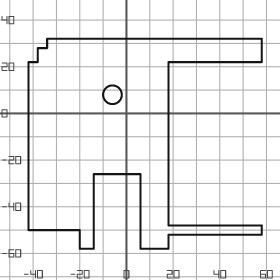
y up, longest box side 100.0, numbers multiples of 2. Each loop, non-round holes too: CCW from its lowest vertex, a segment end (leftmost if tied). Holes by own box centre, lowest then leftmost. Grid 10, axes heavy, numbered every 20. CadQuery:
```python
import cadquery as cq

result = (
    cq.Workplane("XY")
    .moveTo(-20.0, -58.0)
    .lineTo(-14.0, -58.0)
    .lineTo(-14.0, -26.0)
    .lineTo(6.0, -26.0)
    .lineTo(6.0, -58.0)
    .lineTo(18.0, -58.0)
    .lineTo(18.0, -52.0)
    .lineTo(58.0, -52.0)
    .lineTo(58.0, -48.0)
    .lineTo(18.0, -48.0)
    .lineTo(18.0, 22.0)
    .lineTo(58.0, 22.0)
    .lineTo(58.0, 32.0)
    .lineTo(-34.0, 32.0)
    .lineTo(-34.0, 28.0)
    .lineTo(-38.0, 28.0)
    .lineTo(-38.0, 22.0)
    .lineTo(-42.0, 22.0)
    .lineTo(-42.0, -50.0)
    .lineTo(-20.0, -50.0)
    .close()
    .moveTo(-6.0, 8.0)
    .circle(4.0)
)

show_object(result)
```